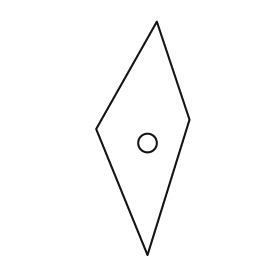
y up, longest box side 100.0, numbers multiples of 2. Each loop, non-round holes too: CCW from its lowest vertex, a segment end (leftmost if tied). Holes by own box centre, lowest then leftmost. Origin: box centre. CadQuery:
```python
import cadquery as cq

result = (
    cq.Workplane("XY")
    .moveTo(2.0, -50.0)
    .lineTo(20.0, 8.0)
    .lineTo(6.0, 50.0)
    .lineTo(-20.0, 4.0)
    .close()
    .moveTo(2.0, -2.0)
    .circle(4.0)
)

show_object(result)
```